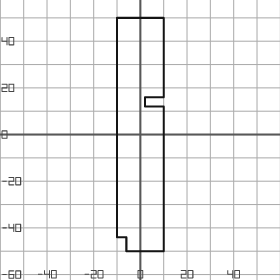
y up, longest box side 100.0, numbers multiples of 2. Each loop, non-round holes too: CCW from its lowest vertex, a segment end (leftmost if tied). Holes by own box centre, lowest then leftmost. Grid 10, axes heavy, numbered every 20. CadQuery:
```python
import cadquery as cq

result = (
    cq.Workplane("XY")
    .moveTo(-6.0, -50.0)
    .lineTo(10.0, -50.0)
    .lineTo(10.0, 12.0)
    .lineTo(2.0, 12.0)
    .lineTo(2.0, 16.0)
    .lineTo(10.0, 16.0)
    .lineTo(10.0, 50.0)
    .lineTo(-10.0, 50.0)
    .lineTo(-10.0, -44.0)
    .lineTo(-6.0, -44.0)
    .close()
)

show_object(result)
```